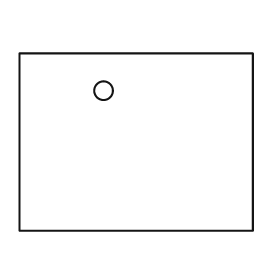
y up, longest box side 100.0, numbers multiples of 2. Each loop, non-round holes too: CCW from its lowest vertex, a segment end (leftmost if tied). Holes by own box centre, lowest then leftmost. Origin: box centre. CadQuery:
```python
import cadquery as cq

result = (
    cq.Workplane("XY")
    .moveTo(-50.0, -38.0)
    .lineTo(50.0, -38.0)
    .lineTo(50.0, 38.0)
    .lineTo(-50.0, 38.0)
    .close()
    .moveTo(-14.0, 22.0)
    .circle(4.0)
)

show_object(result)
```